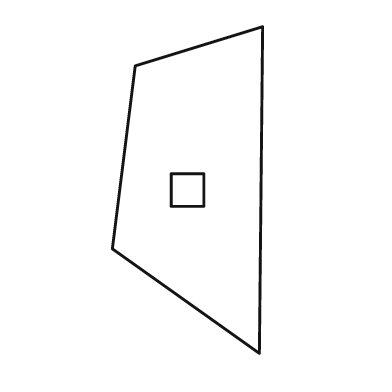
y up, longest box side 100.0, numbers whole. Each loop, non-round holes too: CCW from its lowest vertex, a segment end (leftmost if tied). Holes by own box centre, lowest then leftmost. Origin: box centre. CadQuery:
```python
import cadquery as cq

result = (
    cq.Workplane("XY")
    .moveTo(22.0, -50.0)
    .lineTo(23.0, 50.0)
    .lineTo(-16.0, 38.0)
    .lineTo(-23.0, -18.0)
    .close()
    .moveTo(-5.0, -5.0)
    .lineTo(5.0, -5.0)
    .lineTo(5.0, 5.0)
    .lineTo(-5.0, 5.0)
    .close()
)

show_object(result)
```